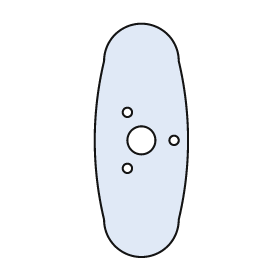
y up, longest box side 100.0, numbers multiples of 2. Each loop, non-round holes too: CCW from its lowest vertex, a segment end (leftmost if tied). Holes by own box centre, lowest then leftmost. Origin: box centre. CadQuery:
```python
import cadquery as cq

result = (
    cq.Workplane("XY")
    .moveTo(-16.0, -34.0)
    .threePointArc((0.0, -50.0), (16.0, -34.0))
    .threePointArc((20.0, 0.0), (16.0, 34.0))
    .threePointArc((0.0, 50.0), (-16.0, 34.0))
    .threePointArc((-20.0, 0.0), (-16.0, -34.0))
    .close()
    .moveTo(-6.0, -12.0)
    .circle(2.0)
    .moveTo(0.0, 0.0)
    .circle(6.0)
    .moveTo(14.0, 0.0)
    .circle(2.0)
    .moveTo(-6.0, 12.0)
    .circle(2.0)
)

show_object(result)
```